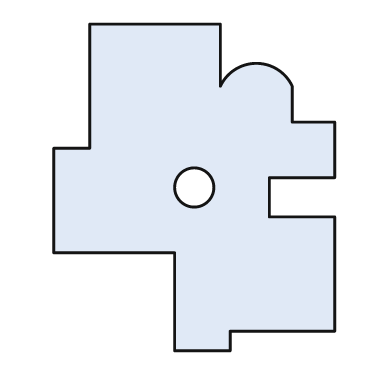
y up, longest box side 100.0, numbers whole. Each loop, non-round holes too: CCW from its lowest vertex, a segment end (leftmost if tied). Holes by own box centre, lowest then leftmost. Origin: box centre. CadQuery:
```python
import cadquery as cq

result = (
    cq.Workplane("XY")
    .moveTo(-6.0, -50.0)
    .lineTo(11.0, -50.0)
    .lineTo(11.0, -44.0)
    .lineTo(43.0, -44.0)
    .lineTo(43.0, -9.0)
    .lineTo(23.0, -9.0)
    .lineTo(23.0, 3.0)
    .lineTo(43.0, 3.0)
    .lineTo(43.0, 20.0)
    .lineTo(30.0, 20.0)
    .lineTo(30.0, 31.0)
    .threePointArc((19.0, 38.0), (8.0, 31.0))
    .lineTo(8.0, 50.0)
    .lineTo(-32.0, 50.0)
    .lineTo(-32.0, 12.0)
    .lineTo(-43.0, 12.0)
    .lineTo(-43.0, -20.0)
    .lineTo(-6.0, -20.0)
    .close()
    .moveTo(0.0, 0.0)
    .circle(6.0)
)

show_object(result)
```